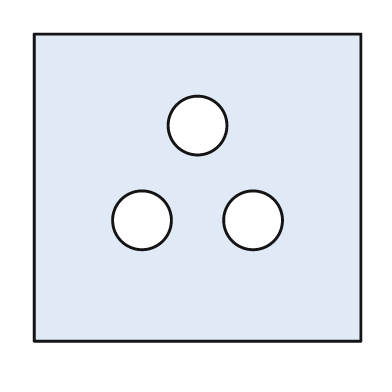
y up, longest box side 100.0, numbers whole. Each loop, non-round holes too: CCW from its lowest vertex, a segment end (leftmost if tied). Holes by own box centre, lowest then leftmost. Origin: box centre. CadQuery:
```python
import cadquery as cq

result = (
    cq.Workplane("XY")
    .moveTo(-50.0, -47.0)
    .lineTo(50.0, -47.0)
    .lineTo(50.0, 47.0)
    .lineTo(-50.0, 47.0)
    .close()
    .moveTo(-17.0, -10.0)
    .circle(9.0)
    .moveTo(17.0, -10.0)
    .circle(9.0)
    .moveTo(0.0, 19.0)
    .circle(9.0)
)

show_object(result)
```